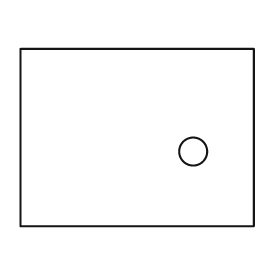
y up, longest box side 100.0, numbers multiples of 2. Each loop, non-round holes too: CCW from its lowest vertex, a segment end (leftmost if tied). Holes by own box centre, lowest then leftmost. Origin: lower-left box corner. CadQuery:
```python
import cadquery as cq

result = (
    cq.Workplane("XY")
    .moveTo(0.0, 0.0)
    .lineTo(100.0, 0.0)
    .lineTo(100.0, 76.0)
    .lineTo(0.0, 76.0)
    .close()
    .moveTo(74.0, 32.0)
    .circle(6.0)
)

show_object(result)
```